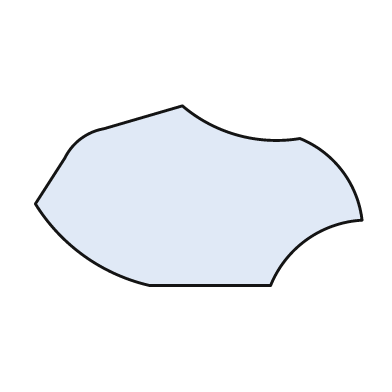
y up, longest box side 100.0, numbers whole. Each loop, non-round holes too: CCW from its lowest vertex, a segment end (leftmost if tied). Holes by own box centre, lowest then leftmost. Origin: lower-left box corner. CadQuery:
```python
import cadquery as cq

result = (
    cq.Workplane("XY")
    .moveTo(35.0, 0.0)
    .lineTo(72.0, 0.0)
    .threePointArc((83.0, 14.0), (100.0, 20.0))
    .threePointArc((94.0, 35.0), (81.0, 45.0))
    .threePointArc((62.0, 46.0), (45.0, 55.0))
    .lineTo(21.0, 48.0)
    .threePointArc((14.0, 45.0), (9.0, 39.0))
    .lineTo(0.0, 25.0)
    .threePointArc((15.0, 9.0), (35.0, 0.0))
    .close()
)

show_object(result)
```